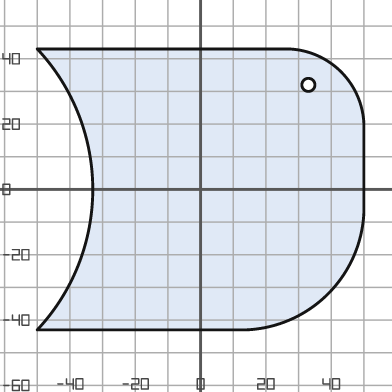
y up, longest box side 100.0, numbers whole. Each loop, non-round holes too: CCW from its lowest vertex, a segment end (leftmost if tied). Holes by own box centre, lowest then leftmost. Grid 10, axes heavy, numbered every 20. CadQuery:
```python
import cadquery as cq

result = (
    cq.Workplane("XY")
    .moveTo(-50.0, -43.0)
    .lineTo(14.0, -43.0)
    .threePointArc((39.0, -32.0), (50.0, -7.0))
    .lineTo(50.0, 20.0)
    .threePointArc((43.0, 36.0), (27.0, 43.0))
    .lineTo(-50.0, 43.0)
    .threePointArc((-33.0, 0.0), (-50.0, -43.0))
    .close()
    .moveTo(33.0, 32.0)
    .circle(2.0)
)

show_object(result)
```